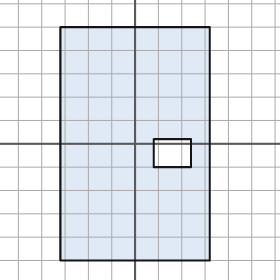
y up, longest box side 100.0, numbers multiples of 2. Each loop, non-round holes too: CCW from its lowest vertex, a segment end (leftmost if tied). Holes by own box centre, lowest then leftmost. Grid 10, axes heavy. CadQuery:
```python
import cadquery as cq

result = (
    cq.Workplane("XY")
    .moveTo(-32.0, -50.0)
    .lineTo(32.0, -50.0)
    .lineTo(32.0, 50.0)
    .lineTo(-32.0, 50.0)
    .close()
    .moveTo(8.0, -10.0)
    .lineTo(24.0, -10.0)
    .lineTo(24.0, 2.0)
    .lineTo(8.0, 2.0)
    .close()
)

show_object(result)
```